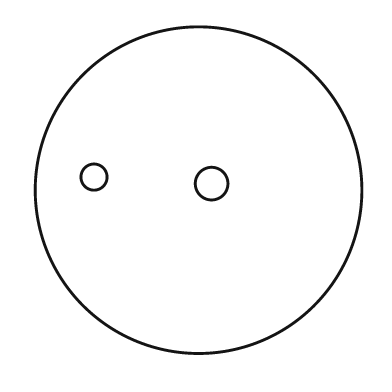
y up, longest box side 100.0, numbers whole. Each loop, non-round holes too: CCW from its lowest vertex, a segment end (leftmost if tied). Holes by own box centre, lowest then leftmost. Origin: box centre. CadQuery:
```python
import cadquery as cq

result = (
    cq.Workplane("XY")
    .moveTo(0.0, 0.0)
    .circle(50.0)
    .moveTo(4.0, 2.0)
    .circle(5.0)
    .moveTo(-32.0, 4.0)
    .circle(4.0)
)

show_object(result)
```